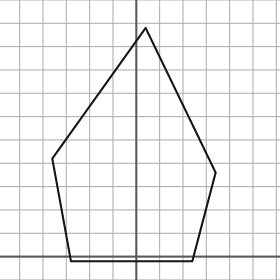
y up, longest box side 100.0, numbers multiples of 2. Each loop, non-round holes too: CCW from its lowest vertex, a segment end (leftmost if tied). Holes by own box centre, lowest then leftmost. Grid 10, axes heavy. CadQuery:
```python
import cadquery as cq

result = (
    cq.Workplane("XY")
    .moveTo(-28.0, -2.0)
    .lineTo(24.0, -2.0)
    .lineTo(34.0, 36.0)
    .lineTo(4.0, 98.0)
    .lineTo(-36.0, 42.0)
    .close()
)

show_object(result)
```